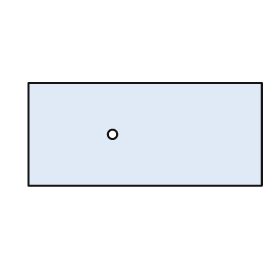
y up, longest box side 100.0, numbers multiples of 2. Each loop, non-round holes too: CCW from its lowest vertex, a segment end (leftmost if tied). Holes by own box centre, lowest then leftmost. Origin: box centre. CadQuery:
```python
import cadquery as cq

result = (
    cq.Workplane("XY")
    .moveTo(-50.0, -22.0)
    .lineTo(50.0, -22.0)
    .lineTo(50.0, 22.0)
    .lineTo(-50.0, 22.0)
    .close()
    .moveTo(-14.0, 0.0)
    .circle(2.0)
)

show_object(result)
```